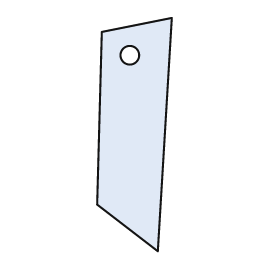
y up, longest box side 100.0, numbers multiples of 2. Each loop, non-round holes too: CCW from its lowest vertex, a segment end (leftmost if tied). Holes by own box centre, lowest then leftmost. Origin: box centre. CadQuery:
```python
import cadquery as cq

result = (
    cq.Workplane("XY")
    .moveTo(10.0, -50.0)
    .lineTo(16.0, 50.0)
    .lineTo(-14.0, 44.0)
    .lineTo(-16.0, -30.0)
    .close()
    .moveTo(-2.0, 34.0)
    .circle(4.0)
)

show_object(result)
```